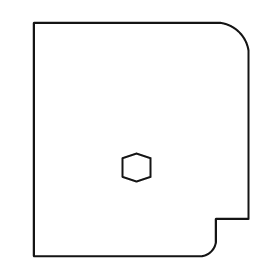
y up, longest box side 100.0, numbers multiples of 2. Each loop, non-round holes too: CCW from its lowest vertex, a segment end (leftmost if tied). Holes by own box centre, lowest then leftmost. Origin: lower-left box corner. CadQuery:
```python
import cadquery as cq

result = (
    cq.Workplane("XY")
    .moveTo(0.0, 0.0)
    .lineTo(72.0, 0.0)
    .threePointArc((76.0, 2.0), (78.0, 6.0))
    .lineTo(78.0, 16.0)
    .lineTo(92.0, 16.0)
    .lineTo(92.0, 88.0)
    .threePointArc((88.0, 96.0), (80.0, 100.0))
    .lineTo(0.0, 100.0)
    .close()
    .moveTo(44.0, 32.0)
    .lineTo(50.0, 34.0)
    .lineTo(50.0, 42.0)
    .lineTo(44.0, 44.0)
    .lineTo(38.0, 42.0)
    .lineTo(38.0, 34.0)
    .close()
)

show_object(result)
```